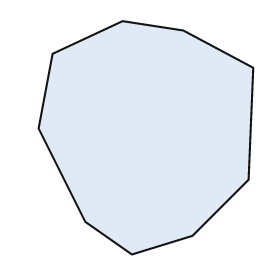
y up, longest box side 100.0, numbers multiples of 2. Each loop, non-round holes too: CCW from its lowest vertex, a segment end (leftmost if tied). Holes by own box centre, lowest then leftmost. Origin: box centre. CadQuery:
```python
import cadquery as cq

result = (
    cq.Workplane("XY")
    .moveTo(-6.0, -50.0)
    .lineTo(20.0, -42.0)
    .lineTo(44.0, -18.0)
    .lineTo(46.0, 30.0)
    .lineTo(16.0, 46.0)
    .lineTo(-10.0, 50.0)
    .lineTo(-40.0, 36.0)
    .lineTo(-46.0, 4.0)
    .lineTo(-26.0, -36.0)
    .close()
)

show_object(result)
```